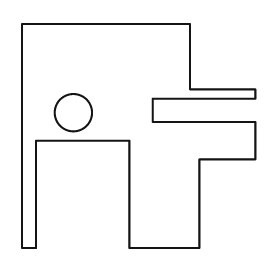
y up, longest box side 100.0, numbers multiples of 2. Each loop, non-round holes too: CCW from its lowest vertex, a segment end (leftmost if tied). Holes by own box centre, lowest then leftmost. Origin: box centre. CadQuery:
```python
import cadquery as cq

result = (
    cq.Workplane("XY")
    .moveTo(-50.0, -48.0)
    .lineTo(-44.0, -48.0)
    .lineTo(-44.0, -2.0)
    .lineTo(-4.0, -2.0)
    .lineTo(-4.0, -48.0)
    .lineTo(26.0, -48.0)
    .lineTo(26.0, -10.0)
    .lineTo(50.0, -10.0)
    .lineTo(50.0, 6.0)
    .lineTo(6.0, 6.0)
    .lineTo(6.0, 16.0)
    .lineTo(50.0, 16.0)
    .lineTo(50.0, 20.0)
    .lineTo(22.0, 20.0)
    .lineTo(22.0, 48.0)
    .lineTo(-50.0, 48.0)
    .close()
    .moveTo(-28.0, 10.0)
    .circle(8.0)
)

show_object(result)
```